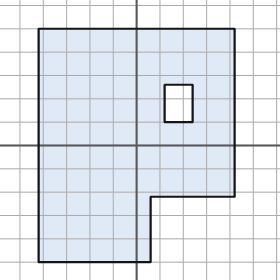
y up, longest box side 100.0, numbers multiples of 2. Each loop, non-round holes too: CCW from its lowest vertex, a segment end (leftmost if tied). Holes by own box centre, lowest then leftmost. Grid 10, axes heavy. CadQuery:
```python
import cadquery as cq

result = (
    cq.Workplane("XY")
    .moveTo(-42.0, -50.0)
    .lineTo(6.0, -50.0)
    .lineTo(6.0, -22.0)
    .lineTo(42.0, -22.0)
    .lineTo(42.0, 50.0)
    .lineTo(-42.0, 50.0)
    .close()
    .moveTo(12.0, 10.0)
    .lineTo(24.0, 10.0)
    .lineTo(24.0, 26.0)
    .lineTo(12.0, 26.0)
    .close()
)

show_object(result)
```